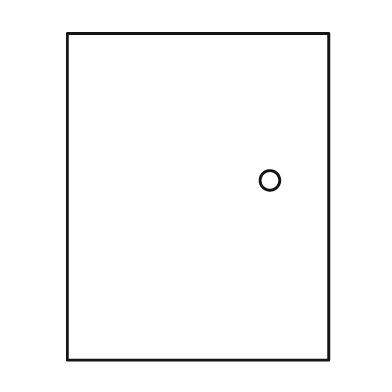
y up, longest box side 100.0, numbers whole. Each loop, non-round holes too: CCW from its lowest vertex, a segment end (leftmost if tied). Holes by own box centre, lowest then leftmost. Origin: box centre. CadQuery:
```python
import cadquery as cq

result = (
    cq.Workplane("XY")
    .moveTo(-40.0, -50.0)
    .lineTo(40.0, -50.0)
    .lineTo(40.0, 50.0)
    .lineTo(-40.0, 50.0)
    .close()
    .moveTo(22.0, 5.0)
    .circle(3.0)
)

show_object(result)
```